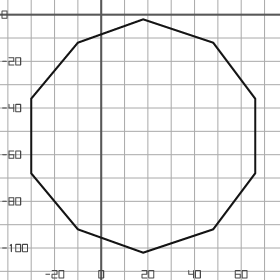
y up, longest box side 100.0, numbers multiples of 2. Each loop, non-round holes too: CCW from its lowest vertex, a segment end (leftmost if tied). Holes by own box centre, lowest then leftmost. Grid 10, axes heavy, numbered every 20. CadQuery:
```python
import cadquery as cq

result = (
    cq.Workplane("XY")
    .moveTo(18.0, -102.0)
    .lineTo(48.0, -92.0)
    .lineTo(66.0, -68.0)
    .lineTo(66.0, -36.0)
    .lineTo(48.0, -12.0)
    .lineTo(18.0, -2.0)
    .lineTo(-10.0, -12.0)
    .lineTo(-30.0, -36.0)
    .lineTo(-30.0, -68.0)
    .lineTo(-10.0, -92.0)
    .close()
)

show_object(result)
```